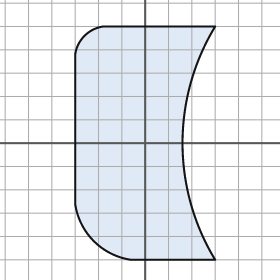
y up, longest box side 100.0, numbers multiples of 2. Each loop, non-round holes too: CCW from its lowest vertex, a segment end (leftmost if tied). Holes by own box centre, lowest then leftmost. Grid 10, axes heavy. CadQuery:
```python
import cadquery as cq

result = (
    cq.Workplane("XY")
    .moveTo(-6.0, -50.0)
    .lineTo(30.0, -50.0)
    .threePointArc((16.0, 0.0), (30.0, 50.0))
    .lineTo(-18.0, 50.0)
    .threePointArc((-26.0, 46.0), (-30.0, 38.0))
    .lineTo(-30.0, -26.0)
    .threePointArc((-22.0, -42.0), (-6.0, -50.0))
    .close()
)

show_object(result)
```